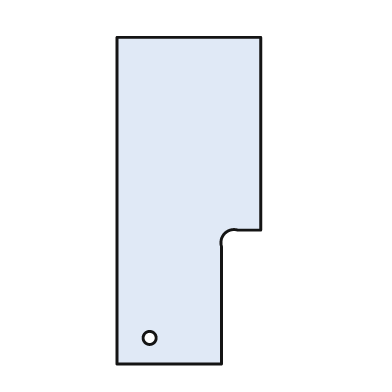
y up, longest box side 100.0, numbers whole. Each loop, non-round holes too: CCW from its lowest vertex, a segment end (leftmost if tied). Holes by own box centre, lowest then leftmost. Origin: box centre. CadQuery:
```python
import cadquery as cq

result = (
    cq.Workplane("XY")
    .moveTo(-22.0, -50.0)
    .lineTo(10.0, -50.0)
    .lineTo(10.0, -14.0)
    .threePointArc((11.0, -10.0), (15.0, -9.0))
    .lineTo(22.0, -9.0)
    .lineTo(22.0, 50.0)
    .lineTo(-22.0, 50.0)
    .close()
    .moveTo(-12.0, -42.0)
    .circle(2.0)
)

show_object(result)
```